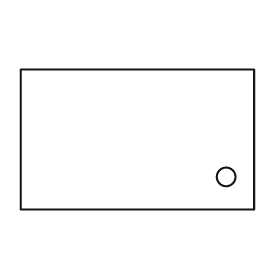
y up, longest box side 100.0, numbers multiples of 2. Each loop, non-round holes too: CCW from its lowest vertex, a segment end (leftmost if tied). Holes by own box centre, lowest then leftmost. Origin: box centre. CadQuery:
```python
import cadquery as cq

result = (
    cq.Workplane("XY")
    .moveTo(-50.0, -30.0)
    .lineTo(50.0, -30.0)
    .lineTo(50.0, 30.0)
    .lineTo(-50.0, 30.0)
    .close()
    .moveTo(38.0, -16.0)
    .circle(4.0)
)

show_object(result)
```